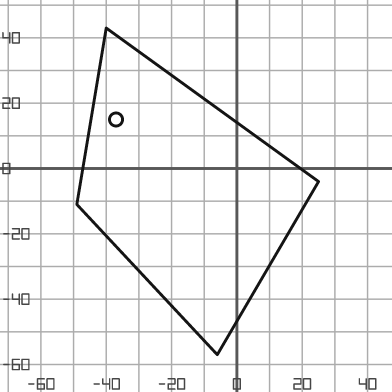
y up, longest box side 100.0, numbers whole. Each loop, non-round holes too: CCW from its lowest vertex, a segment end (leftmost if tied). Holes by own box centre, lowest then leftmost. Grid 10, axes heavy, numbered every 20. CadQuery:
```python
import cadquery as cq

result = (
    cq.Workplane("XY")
    .moveTo(-6.0, -57.0)
    .lineTo(25.0, -4.0)
    .lineTo(-40.0, 43.0)
    .lineTo(-49.0, -11.0)
    .close()
    .moveTo(-37.0, 15.0)
    .circle(2.0)
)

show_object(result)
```